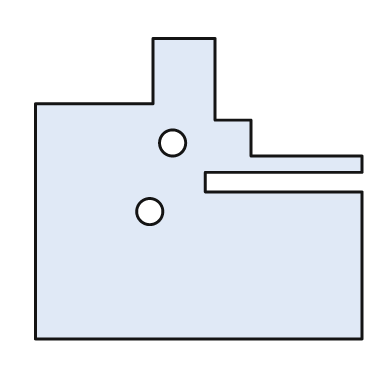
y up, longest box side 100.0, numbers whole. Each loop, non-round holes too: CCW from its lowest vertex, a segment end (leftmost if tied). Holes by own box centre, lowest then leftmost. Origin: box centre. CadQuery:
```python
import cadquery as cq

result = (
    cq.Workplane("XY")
    .moveTo(-50.0, -46.0)
    .lineTo(50.0, -46.0)
    .lineTo(50.0, -1.0)
    .lineTo(2.0, -1.0)
    .lineTo(2.0, 5.0)
    .lineTo(50.0, 5.0)
    .lineTo(50.0, 10.0)
    .lineTo(16.0, 10.0)
    .lineTo(16.0, 21.0)
    .lineTo(5.0, 21.0)
    .lineTo(5.0, 46.0)
    .lineTo(-14.0, 46.0)
    .lineTo(-14.0, 26.0)
    .lineTo(-50.0, 26.0)
    .close()
    .moveTo(-15.0, -7.0)
    .circle(4.0)
    .moveTo(-8.0, 14.0)
    .circle(4.0)
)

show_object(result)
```